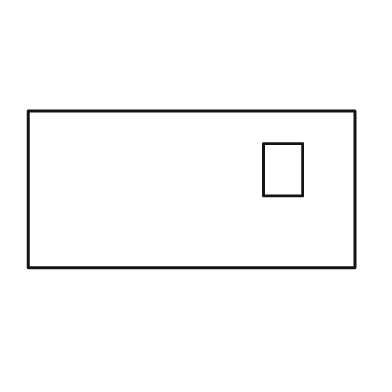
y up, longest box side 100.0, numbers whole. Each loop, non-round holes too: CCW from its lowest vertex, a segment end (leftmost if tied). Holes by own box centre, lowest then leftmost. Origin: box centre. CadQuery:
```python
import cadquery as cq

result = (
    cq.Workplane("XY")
    .moveTo(-50.0, -24.0)
    .lineTo(50.0, -24.0)
    .lineTo(50.0, 24.0)
    .lineTo(-50.0, 24.0)
    .close()
    .moveTo(22.0, -2.0)
    .lineTo(34.0, -2.0)
    .lineTo(34.0, 14.0)
    .lineTo(22.0, 14.0)
    .close()
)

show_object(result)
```